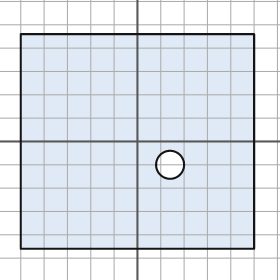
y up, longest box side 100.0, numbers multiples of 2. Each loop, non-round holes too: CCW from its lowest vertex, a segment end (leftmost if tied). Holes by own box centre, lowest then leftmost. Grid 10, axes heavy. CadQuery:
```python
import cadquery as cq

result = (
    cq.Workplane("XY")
    .moveTo(-50.0, -46.0)
    .lineTo(50.0, -46.0)
    .lineTo(50.0, 46.0)
    .lineTo(-50.0, 46.0)
    .close()
    .moveTo(14.0, -10.0)
    .circle(6.0)
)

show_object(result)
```